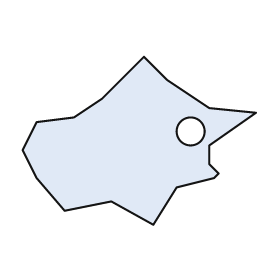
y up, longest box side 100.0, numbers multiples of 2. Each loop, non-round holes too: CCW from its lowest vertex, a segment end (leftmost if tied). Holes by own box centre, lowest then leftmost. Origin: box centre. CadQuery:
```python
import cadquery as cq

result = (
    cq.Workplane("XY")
    .moveTo(6.0, -36.0)
    .lineTo(16.0, -20.0)
    .lineTo(32.0, -16.0)
    .lineTo(34.0, -14.0)
    .lineTo(30.0, -10.0)
    .lineTo(30.0, -2.0)
    .lineTo(50.0, 12.0)
    .lineTo(30.0, 14.0)
    .lineTo(12.0, 26.0)
    .lineTo(2.0, 36.0)
    .lineTo(-16.0, 18.0)
    .lineTo(-28.0, 10.0)
    .lineTo(-44.0, 8.0)
    .lineTo(-50.0, -4.0)
    .lineTo(-44.0, -16.0)
    .lineTo(-32.0, -30.0)
    .lineTo(-12.0, -26.0)
    .close()
    .moveTo(22.0, 4.0)
    .circle(6.0)
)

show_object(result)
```